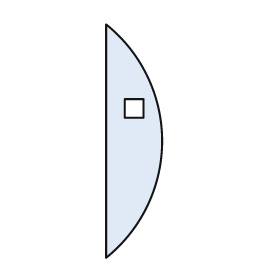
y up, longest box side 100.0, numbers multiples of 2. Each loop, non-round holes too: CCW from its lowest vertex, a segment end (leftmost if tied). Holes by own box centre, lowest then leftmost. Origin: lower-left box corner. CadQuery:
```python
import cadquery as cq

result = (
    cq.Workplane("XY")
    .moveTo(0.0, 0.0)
    .threePointArc((24.0, 50.0), (0.0, 100.0))
    .close()
    .moveTo(8.0, 60.0)
    .lineTo(16.0, 60.0)
    .lineTo(16.0, 68.0)
    .lineTo(8.0, 68.0)
    .close()
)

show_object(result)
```